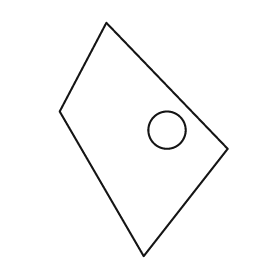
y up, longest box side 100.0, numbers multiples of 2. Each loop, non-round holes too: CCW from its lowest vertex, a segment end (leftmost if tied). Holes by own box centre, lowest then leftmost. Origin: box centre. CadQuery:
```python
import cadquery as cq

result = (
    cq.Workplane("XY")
    .moveTo(0.0, -50.0)
    .lineTo(36.0, -4.0)
    .lineTo(-16.0, 50.0)
    .lineTo(-36.0, 12.0)
    .close()
    .moveTo(10.0, 4.0)
    .circle(8.0)
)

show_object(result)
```